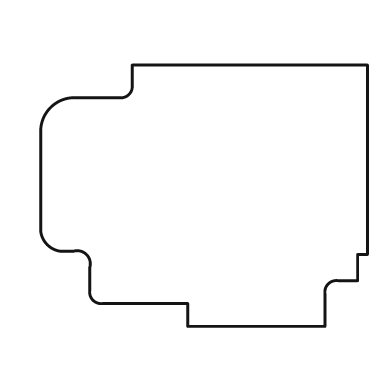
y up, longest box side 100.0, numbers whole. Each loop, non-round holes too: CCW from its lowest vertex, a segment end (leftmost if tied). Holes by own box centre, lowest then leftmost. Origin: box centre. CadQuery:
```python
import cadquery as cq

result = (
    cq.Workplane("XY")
    .moveTo(-5.0, -40.0)
    .lineTo(37.0, -40.0)
    .lineTo(37.0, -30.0)
    .threePointArc((38.0, -27.0), (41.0, -26.0))
    .lineTo(47.0, -26.0)
    .lineTo(47.0, -18.0)
    .lineTo(50.0, -18.0)
    .lineTo(50.0, 40.0)
    .lineTo(-22.0, 40.0)
    .lineTo(-22.0, 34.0)
    .threePointArc((-23.0, 31.0), (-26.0, 30.0))
    .lineTo(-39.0, 30.0)
    .threePointArc((-47.0, 27.0), (-50.0, 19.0))
    .lineTo(-50.0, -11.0)
    .threePointArc((-48.0, -15.0), (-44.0, -17.0))
    .lineTo(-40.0, -17.0)
    .threePointArc((-36.0, -18.0), (-35.0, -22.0))
    .lineTo(-35.0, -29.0)
    .threePointArc((-34.0, -32.0), (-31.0, -33.0))
    .lineTo(-5.0, -33.0)
    .close()
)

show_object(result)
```